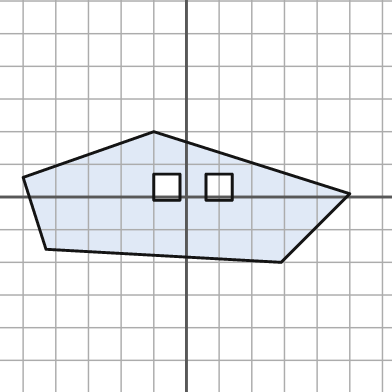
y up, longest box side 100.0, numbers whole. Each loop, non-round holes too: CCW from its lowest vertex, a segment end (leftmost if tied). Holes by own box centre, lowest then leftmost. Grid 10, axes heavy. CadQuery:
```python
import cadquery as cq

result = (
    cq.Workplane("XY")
    .moveTo(29.0, -20.0)
    .lineTo(50.0, 1.0)
    .lineTo(-10.0, 20.0)
    .lineTo(-50.0, 6.0)
    .lineTo(-43.0, -16.0)
    .close()
    .moveTo(-10.0, -1.0)
    .lineTo(-2.0, -1.0)
    .lineTo(-2.0, 7.0)
    .lineTo(-10.0, 7.0)
    .close()
    .moveTo(6.0, -1.0)
    .lineTo(14.0, -1.0)
    .lineTo(14.0, 7.0)
    .lineTo(6.0, 7.0)
    .close()
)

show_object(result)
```